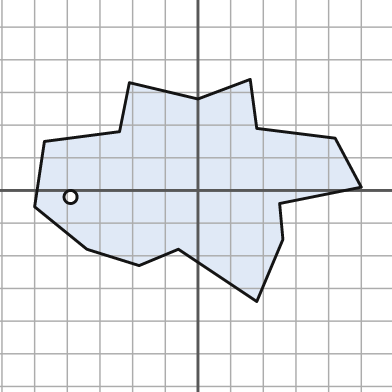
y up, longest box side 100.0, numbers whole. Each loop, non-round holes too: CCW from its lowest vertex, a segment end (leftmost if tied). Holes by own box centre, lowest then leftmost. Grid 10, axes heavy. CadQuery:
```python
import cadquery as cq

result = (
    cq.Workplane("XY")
    .moveTo(18.0, -34.0)
    .lineTo(26.0, -15.0)
    .lineTo(25.0, -4.0)
    .lineTo(50.0, 1.0)
    .lineTo(42.0, 16.0)
    .lineTo(18.0, 19.0)
    .lineTo(16.0, 34.0)
    .lineTo(0.0, 28.0)
    .lineTo(-21.0, 33.0)
    .lineTo(-24.0, 18.0)
    .lineTo(-47.0, 15.0)
    .lineTo(-50.0, -5.0)
    .lineTo(-34.0, -18.0)
    .lineTo(-18.0, -23.0)
    .lineTo(-6.0, -18.0)
    .close()
    .moveTo(-39.0, -2.0)
    .circle(2.0)
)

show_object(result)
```